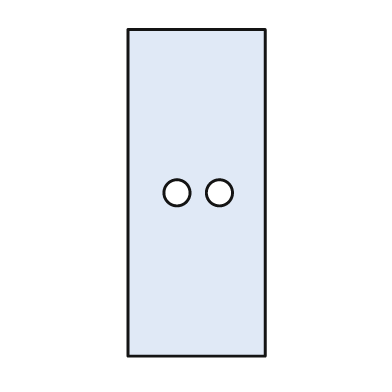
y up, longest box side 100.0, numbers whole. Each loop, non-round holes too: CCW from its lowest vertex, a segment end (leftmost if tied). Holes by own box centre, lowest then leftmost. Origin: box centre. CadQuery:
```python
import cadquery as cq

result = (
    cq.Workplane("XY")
    .moveTo(-21.0, -50.0)
    .lineTo(21.0, -50.0)
    .lineTo(21.0, 50.0)
    .lineTo(-21.0, 50.0)
    .close()
    .moveTo(-6.0, 0.0)
    .circle(4.0)
    .moveTo(7.0, 0.0)
    .circle(4.0)
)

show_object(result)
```